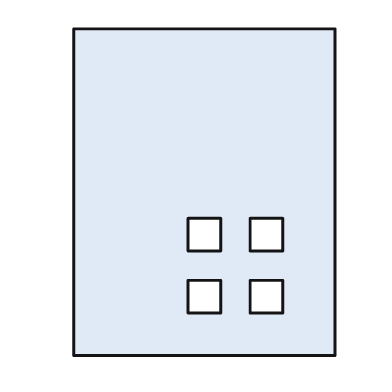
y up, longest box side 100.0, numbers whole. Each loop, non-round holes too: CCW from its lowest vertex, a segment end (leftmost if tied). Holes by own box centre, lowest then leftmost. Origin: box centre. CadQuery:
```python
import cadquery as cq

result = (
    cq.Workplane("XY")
    .moveTo(-40.0, -50.0)
    .lineTo(40.0, -50.0)
    .lineTo(40.0, 50.0)
    .lineTo(-40.0, 50.0)
    .close()
    .moveTo(-5.0, -37.0)
    .lineTo(5.0, -37.0)
    .lineTo(5.0, -27.0)
    .lineTo(-5.0, -27.0)
    .close()
    .moveTo(14.0, -37.0)
    .lineTo(24.0, -37.0)
    .lineTo(24.0, -27.0)
    .lineTo(14.0, -27.0)
    .close()
    .moveTo(-5.0, -18.0)
    .lineTo(5.0, -18.0)
    .lineTo(5.0, -8.0)
    .lineTo(-5.0, -8.0)
    .close()
    .moveTo(14.0, -18.0)
    .lineTo(24.0, -18.0)
    .lineTo(24.0, -8.0)
    .lineTo(14.0, -8.0)
    .close()
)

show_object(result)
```